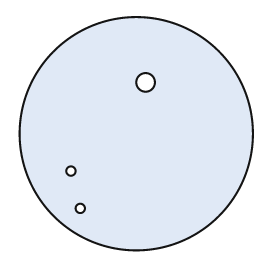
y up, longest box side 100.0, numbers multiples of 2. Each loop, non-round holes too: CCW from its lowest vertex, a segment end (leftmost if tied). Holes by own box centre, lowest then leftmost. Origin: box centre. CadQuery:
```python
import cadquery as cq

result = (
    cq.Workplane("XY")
    .moveTo(0.0, 0.0)
    .circle(50.0)
    .moveTo(-24.0, -32.0)
    .circle(2.0)
    .moveTo(-28.0, -16.0)
    .circle(2.0)
    .moveTo(4.0, 22.0)
    .circle(4.0)
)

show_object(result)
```